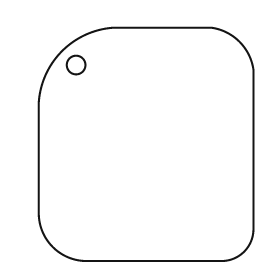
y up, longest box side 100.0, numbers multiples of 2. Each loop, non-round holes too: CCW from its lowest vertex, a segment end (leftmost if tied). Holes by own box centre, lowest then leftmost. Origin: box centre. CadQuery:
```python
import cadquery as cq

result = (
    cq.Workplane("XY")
    .moveTo(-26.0, -50.0)
    .lineTo(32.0, -50.0)
    .threePointArc((42.0, -46.0), (46.0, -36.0))
    .lineTo(46.0, 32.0)
    .threePointArc((40.0, 44.0), (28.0, 50.0))
    .lineTo(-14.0, 50.0)
    .threePointArc((-36.0, 40.0), (-46.0, 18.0))
    .lineTo(-46.0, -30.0)
    .threePointArc((-40.0, -44.0), (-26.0, -50.0))
    .close()
    .moveTo(-30.0, 34.0)
    .circle(4.0)
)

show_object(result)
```